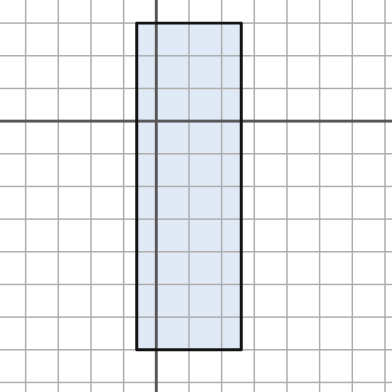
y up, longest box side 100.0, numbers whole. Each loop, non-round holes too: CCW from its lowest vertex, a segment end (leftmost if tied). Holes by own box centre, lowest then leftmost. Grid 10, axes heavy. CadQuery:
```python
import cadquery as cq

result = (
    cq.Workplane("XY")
    .moveTo(-6.0, -70.0)
    .lineTo(26.0, -70.0)
    .lineTo(26.0, 30.0)
    .lineTo(-6.0, 30.0)
    .close()
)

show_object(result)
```